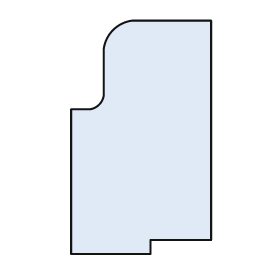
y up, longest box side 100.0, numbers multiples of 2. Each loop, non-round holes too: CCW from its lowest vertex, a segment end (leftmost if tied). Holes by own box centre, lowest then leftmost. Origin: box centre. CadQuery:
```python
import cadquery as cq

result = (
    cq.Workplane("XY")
    .moveTo(-30.0, -50.0)
    .lineTo(4.0, -50.0)
    .lineTo(4.0, -44.0)
    .lineTo(30.0, -44.0)
    .lineTo(30.0, 50.0)
    .lineTo(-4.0, 50.0)
    .threePointArc((-12.0, 46.0), (-16.0, 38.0))
    .lineTo(-16.0, 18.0)
    .threePointArc((-18.0, 14.0), (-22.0, 12.0))
    .lineTo(-30.0, 12.0)
    .close()
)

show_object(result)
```